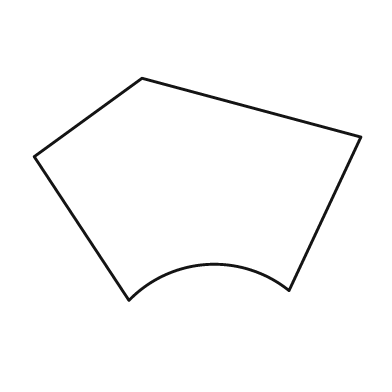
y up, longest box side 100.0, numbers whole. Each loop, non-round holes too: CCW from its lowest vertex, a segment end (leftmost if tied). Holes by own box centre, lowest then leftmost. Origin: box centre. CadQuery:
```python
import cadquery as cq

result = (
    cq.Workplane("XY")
    .moveTo(-21.0, -34.0)
    .threePointArc((3.0, -23.0), (28.0, -31.0))
    .lineTo(50.0, 16.0)
    .lineTo(-17.0, 34.0)
    .lineTo(-50.0, 10.0)
    .close()
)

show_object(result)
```